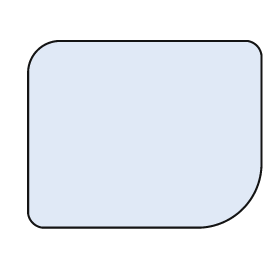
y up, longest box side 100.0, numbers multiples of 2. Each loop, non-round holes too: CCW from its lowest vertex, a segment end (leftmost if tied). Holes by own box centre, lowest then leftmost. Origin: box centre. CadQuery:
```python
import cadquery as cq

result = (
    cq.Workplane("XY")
    .moveTo(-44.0, -40.0)
    .lineTo(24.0, -40.0)
    .threePointArc((42.0, -32.0), (50.0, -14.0))
    .lineTo(50.0, 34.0)
    .threePointArc((48.0, 38.0), (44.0, 40.0))
    .lineTo(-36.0, 40.0)
    .threePointArc((-46.0, 36.0), (-50.0, 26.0))
    .lineTo(-50.0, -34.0)
    .threePointArc((-48.0, -38.0), (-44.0, -40.0))
    .close()
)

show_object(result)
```